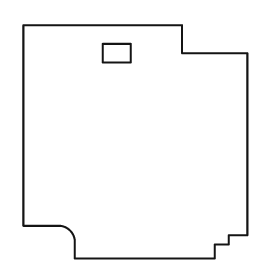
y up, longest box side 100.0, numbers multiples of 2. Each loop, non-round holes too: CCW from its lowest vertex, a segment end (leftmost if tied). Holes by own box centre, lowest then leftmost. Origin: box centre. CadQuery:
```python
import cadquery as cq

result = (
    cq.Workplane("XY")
    .moveTo(-26.0, -50.0)
    .lineTo(34.0, -50.0)
    .lineTo(34.0, -44.0)
    .lineTo(40.0, -44.0)
    .lineTo(40.0, -40.0)
    .lineTo(48.0, -40.0)
    .lineTo(48.0, 38.0)
    .lineTo(20.0, 38.0)
    .lineTo(20.0, 50.0)
    .lineTo(-48.0, 50.0)
    .lineTo(-48.0, -36.0)
    .lineTo(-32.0, -36.0)
    .threePointArc((-28.0, -38.0), (-26.0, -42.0))
    .close()
    .moveTo(-14.0, 34.0)
    .lineTo(-2.0, 34.0)
    .lineTo(-2.0, 42.0)
    .lineTo(-14.0, 42.0)
    .close()
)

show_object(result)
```